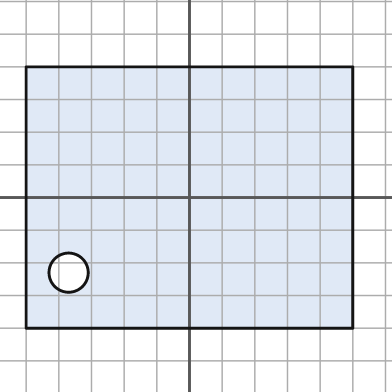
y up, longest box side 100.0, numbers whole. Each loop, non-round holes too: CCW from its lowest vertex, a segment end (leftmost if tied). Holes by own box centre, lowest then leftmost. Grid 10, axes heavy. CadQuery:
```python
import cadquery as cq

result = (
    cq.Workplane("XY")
    .moveTo(-50.0, -40.0)
    .lineTo(50.0, -40.0)
    .lineTo(50.0, 40.0)
    .lineTo(-50.0, 40.0)
    .close()
    .moveTo(-37.0, -23.0)
    .circle(6.0)
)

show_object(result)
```